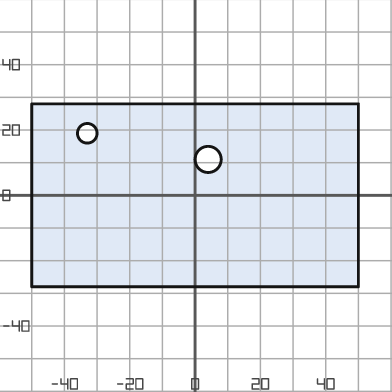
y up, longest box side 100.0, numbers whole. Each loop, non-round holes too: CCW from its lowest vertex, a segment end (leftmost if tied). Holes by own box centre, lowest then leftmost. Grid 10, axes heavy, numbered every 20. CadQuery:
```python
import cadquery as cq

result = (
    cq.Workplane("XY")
    .moveTo(-50.0, -28.0)
    .lineTo(50.0, -28.0)
    .lineTo(50.0, 28.0)
    .lineTo(-50.0, 28.0)
    .close()
    .moveTo(4.0, 11.0)
    .circle(4.0)
    .moveTo(-33.0, 19.0)
    .circle(3.0)
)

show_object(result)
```